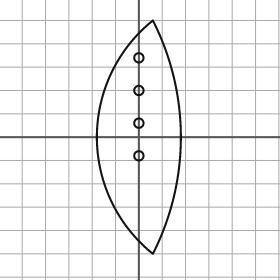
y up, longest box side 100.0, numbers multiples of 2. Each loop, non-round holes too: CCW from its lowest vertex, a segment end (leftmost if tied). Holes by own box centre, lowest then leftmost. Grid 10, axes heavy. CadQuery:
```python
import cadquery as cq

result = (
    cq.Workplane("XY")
    .moveTo(6.0, -50.0)
    .threePointArc((18.0, 0.0), (6.0, 50.0))
    .threePointArc((-18.0, 0.0), (6.0, -50.0))
    .close()
    .moveTo(0.0, -8.0)
    .circle(2.0)
    .moveTo(0.0, 6.0)
    .circle(2.0)
    .moveTo(0.0, 20.0)
    .circle(2.0)
    .moveTo(0.0, 34.0)
    .circle(2.0)
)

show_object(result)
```